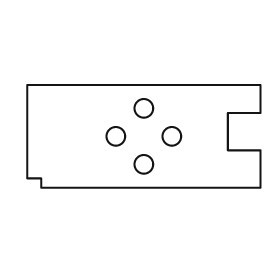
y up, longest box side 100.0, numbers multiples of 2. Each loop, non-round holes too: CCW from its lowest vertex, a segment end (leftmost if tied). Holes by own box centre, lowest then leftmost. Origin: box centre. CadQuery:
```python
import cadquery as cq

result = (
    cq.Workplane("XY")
    .moveTo(-44.0, -22.0)
    .lineTo(50.0, -22.0)
    .lineTo(50.0, -6.0)
    .lineTo(36.0, -6.0)
    .lineTo(36.0, 10.0)
    .lineTo(50.0, 10.0)
    .lineTo(50.0, 22.0)
    .lineTo(-50.0, 22.0)
    .lineTo(-50.0, -18.0)
    .lineTo(-44.0, -18.0)
    .close()
    .moveTo(0.0, -12.0)
    .circle(4.0)
    .moveTo(-12.0, 0.0)
    .circle(4.0)
    .moveTo(12.0, 0.0)
    .circle(4.0)
    .moveTo(0.0, 12.0)
    .circle(4.0)
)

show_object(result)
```